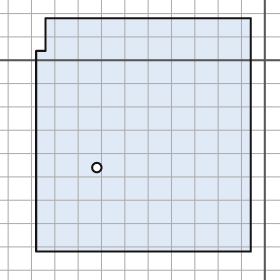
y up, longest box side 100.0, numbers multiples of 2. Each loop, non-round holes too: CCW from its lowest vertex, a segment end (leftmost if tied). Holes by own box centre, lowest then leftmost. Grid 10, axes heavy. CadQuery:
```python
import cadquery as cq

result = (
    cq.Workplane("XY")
    .moveTo(-98.0, -82.0)
    .lineTo(-6.0, -82.0)
    .lineTo(-6.0, 18.0)
    .lineTo(-94.0, 18.0)
    .lineTo(-94.0, 4.0)
    .lineTo(-98.0, 4.0)
    .close()
    .moveTo(-72.0, -46.0)
    .circle(2.0)
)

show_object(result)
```